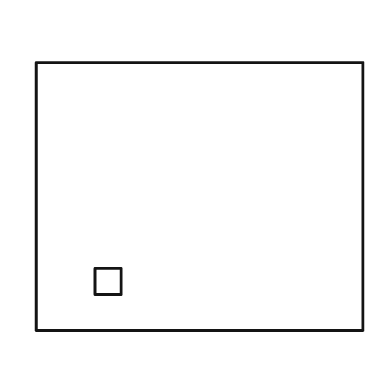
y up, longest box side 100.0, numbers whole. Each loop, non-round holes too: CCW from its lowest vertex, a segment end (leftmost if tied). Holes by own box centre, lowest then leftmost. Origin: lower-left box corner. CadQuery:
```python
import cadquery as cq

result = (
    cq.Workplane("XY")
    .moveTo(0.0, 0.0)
    .lineTo(100.0, 0.0)
    .lineTo(100.0, 82.0)
    .lineTo(0.0, 82.0)
    .close()
    .moveTo(18.0, 11.0)
    .lineTo(26.0, 11.0)
    .lineTo(26.0, 19.0)
    .lineTo(18.0, 19.0)
    .close()
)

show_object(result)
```